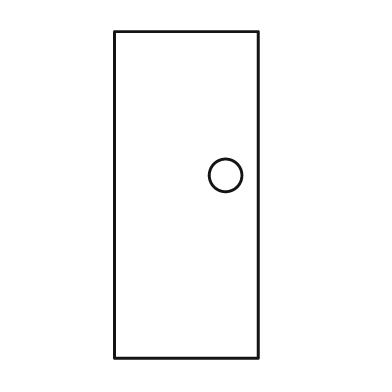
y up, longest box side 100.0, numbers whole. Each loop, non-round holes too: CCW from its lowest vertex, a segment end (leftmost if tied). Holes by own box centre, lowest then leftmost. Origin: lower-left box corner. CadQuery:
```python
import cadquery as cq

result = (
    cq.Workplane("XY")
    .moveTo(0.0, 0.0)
    .lineTo(44.0, 0.0)
    .lineTo(44.0, 100.0)
    .lineTo(0.0, 100.0)
    .close()
    .moveTo(34.0, 56.0)
    .circle(5.0)
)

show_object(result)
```